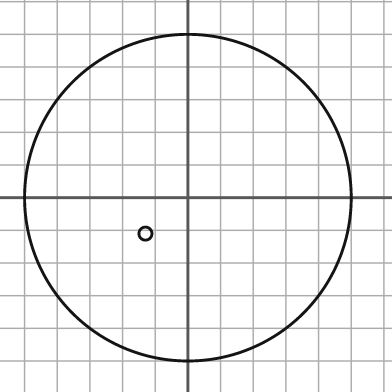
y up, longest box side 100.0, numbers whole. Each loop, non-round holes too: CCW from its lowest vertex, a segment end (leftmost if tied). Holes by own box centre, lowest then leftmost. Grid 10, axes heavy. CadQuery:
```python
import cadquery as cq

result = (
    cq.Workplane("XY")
    .moveTo(0.0, 0.0)
    .circle(50.0)
    .moveTo(-13.0, -11.0)
    .circle(2.0)
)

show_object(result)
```